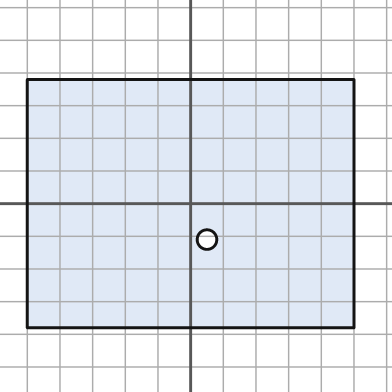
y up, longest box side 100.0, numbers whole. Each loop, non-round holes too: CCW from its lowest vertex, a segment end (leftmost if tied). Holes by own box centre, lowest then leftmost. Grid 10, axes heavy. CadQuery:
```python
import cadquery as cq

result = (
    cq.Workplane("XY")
    .moveTo(-50.0, -38.0)
    .lineTo(50.0, -38.0)
    .lineTo(50.0, 38.0)
    .lineTo(-50.0, 38.0)
    .close()
    .moveTo(5.0, -11.0)
    .circle(3.0)
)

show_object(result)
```